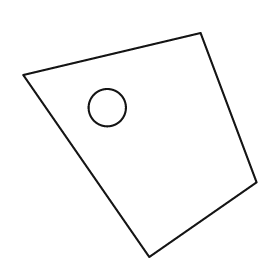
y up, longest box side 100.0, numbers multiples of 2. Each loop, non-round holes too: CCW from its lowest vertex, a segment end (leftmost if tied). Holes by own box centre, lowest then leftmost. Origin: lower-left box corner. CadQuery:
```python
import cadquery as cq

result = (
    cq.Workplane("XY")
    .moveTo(54.0, 0.0)
    .lineTo(100.0, 32.0)
    .lineTo(76.0, 96.0)
    .lineTo(0.0, 78.0)
    .close()
    .moveTo(36.0, 64.0)
    .circle(8.0)
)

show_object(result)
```